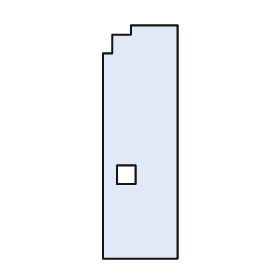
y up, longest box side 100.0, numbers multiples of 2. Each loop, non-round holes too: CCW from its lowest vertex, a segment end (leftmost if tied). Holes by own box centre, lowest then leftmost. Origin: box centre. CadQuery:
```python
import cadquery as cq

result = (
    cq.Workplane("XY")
    .moveTo(-16.0, -50.0)
    .lineTo(16.0, -50.0)
    .lineTo(16.0, 50.0)
    .lineTo(-4.0, 50.0)
    .lineTo(-4.0, 46.0)
    .lineTo(-12.0, 46.0)
    .lineTo(-12.0, 38.0)
    .lineTo(-16.0, 38.0)
    .close()
    .moveTo(-10.0, -18.0)
    .lineTo(-2.0, -18.0)
    .lineTo(-2.0, -10.0)
    .lineTo(-10.0, -10.0)
    .close()
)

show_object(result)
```